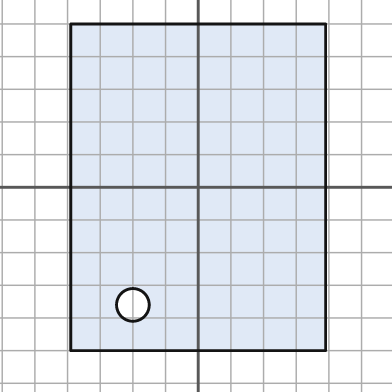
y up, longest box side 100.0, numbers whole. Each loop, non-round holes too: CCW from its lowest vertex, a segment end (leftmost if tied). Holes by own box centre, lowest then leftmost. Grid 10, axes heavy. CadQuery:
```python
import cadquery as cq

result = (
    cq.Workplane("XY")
    .moveTo(-39.0, -50.0)
    .lineTo(39.0, -50.0)
    .lineTo(39.0, 50.0)
    .lineTo(-39.0, 50.0)
    .close()
    .moveTo(-20.0, -36.0)
    .circle(5.0)
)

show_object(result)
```